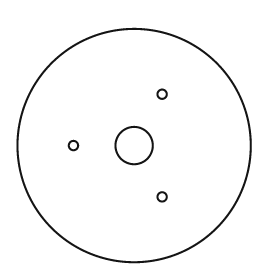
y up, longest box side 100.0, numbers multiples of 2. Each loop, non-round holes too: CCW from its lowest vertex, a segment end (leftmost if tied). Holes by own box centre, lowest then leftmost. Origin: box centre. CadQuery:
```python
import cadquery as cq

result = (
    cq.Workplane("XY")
    .moveTo(0.0, 0.0)
    .circle(50.0)
    .moveTo(12.0, -22.0)
    .circle(2.0)
    .moveTo(-26.0, 0.0)
    .circle(2.0)
    .moveTo(0.0, 0.0)
    .circle(8.0)
    .moveTo(12.0, 22.0)
    .circle(2.0)
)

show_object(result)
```